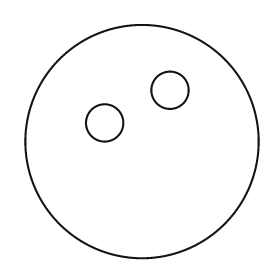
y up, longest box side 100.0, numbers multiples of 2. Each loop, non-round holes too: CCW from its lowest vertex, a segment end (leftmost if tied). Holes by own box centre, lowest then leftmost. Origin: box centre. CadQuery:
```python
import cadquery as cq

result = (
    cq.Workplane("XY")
    .moveTo(0.0, 0.0)
    .circle(50.0)
    .moveTo(-16.0, 8.0)
    .circle(8.0)
    .moveTo(12.0, 22.0)
    .circle(8.0)
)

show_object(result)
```